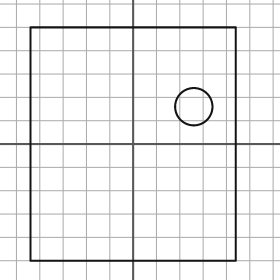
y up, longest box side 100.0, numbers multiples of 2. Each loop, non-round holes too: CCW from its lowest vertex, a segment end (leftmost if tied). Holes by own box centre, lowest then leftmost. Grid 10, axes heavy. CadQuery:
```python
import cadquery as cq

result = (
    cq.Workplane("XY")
    .moveTo(-44.0, -50.0)
    .lineTo(44.0, -50.0)
    .lineTo(44.0, 50.0)
    .lineTo(-44.0, 50.0)
    .close()
    .moveTo(26.0, 16.0)
    .circle(8.0)
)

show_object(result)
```